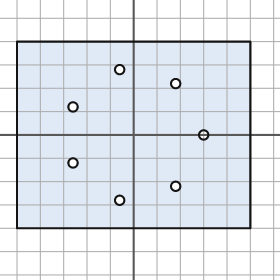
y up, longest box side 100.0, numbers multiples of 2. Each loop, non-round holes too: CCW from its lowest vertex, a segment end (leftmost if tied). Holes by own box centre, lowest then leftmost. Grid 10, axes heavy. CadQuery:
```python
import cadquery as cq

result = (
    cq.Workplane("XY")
    .moveTo(-50.0, -40.0)
    .lineTo(50.0, -40.0)
    .lineTo(50.0, 40.0)
    .lineTo(-50.0, 40.0)
    .close()
    .moveTo(-6.0, -28.0)
    .circle(2.0)
    .moveTo(18.0, -22.0)
    .circle(2.0)
    .moveTo(-26.0, -12.0)
    .circle(2.0)
    .moveTo(30.0, 0.0)
    .circle(2.0)
    .moveTo(-26.0, 12.0)
    .circle(2.0)
    .moveTo(18.0, 22.0)
    .circle(2.0)
    .moveTo(-6.0, 28.0)
    .circle(2.0)
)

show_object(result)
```